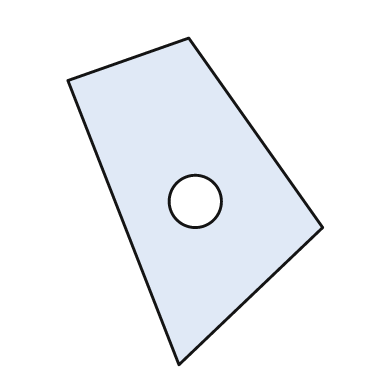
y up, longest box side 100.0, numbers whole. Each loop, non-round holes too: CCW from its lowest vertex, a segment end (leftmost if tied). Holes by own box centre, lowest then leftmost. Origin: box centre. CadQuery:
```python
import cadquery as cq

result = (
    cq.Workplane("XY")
    .moveTo(-5.0, -50.0)
    .lineTo(39.0, -8.0)
    .lineTo(-2.0, 50.0)
    .lineTo(-39.0, 37.0)
    .close()
    .moveTo(0.0, 0.0)
    .circle(8.0)
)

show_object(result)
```